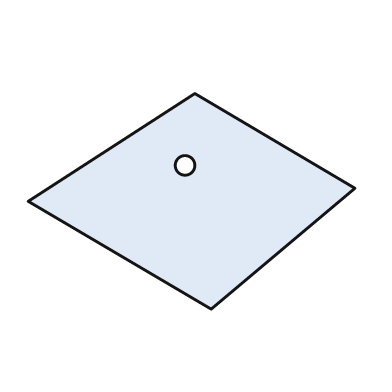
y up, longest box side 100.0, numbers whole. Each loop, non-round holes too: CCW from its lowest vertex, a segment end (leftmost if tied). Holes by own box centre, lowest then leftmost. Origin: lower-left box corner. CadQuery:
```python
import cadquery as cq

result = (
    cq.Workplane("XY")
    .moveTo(56.0, 0.0)
    .lineTo(100.0, 37.0)
    .lineTo(51.0, 66.0)
    .lineTo(0.0, 33.0)
    .close()
    .moveTo(48.0, 44.0)
    .circle(3.0)
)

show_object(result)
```